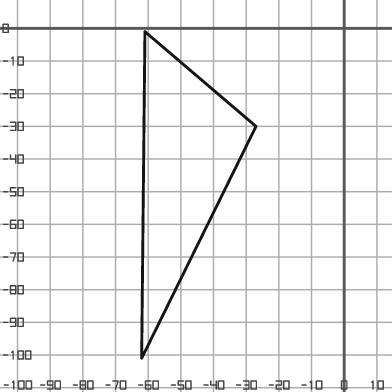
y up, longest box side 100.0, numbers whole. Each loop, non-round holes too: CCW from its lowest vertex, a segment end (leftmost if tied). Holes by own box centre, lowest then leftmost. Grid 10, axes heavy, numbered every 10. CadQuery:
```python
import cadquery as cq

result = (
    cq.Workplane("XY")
    .moveTo(-62.0, -101.0)
    .lineTo(-27.0, -30.0)
    .lineTo(-61.0, -1.0)
    .close()
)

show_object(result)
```